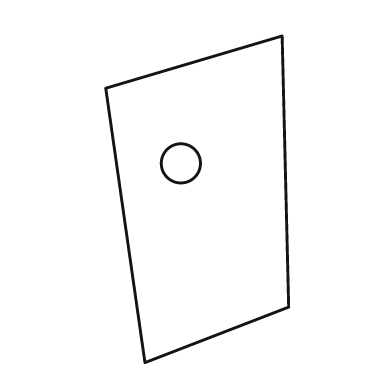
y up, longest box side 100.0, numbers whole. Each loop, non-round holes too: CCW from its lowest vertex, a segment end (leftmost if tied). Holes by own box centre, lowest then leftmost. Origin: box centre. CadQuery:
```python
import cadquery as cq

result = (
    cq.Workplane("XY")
    .moveTo(-16.0, -50.0)
    .lineTo(28.0, -33.0)
    .lineTo(26.0, 50.0)
    .lineTo(-28.0, 34.0)
    .close()
    .moveTo(-5.0, 11.0)
    .circle(6.0)
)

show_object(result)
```